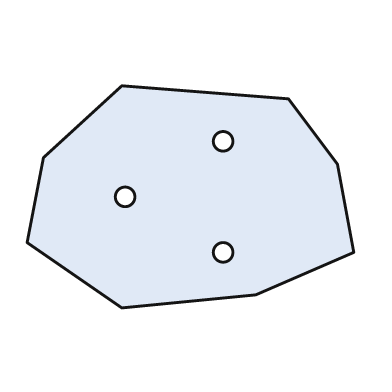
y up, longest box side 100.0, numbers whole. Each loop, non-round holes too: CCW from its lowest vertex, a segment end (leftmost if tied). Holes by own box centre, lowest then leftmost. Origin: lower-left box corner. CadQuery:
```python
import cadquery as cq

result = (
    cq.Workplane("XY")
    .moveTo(29.0, 0.0)
    .lineTo(70.0, 4.0)
    .lineTo(100.0, 17.0)
    .lineTo(95.0, 44.0)
    .lineTo(80.0, 64.0)
    .lineTo(29.0, 68.0)
    .lineTo(5.0, 46.0)
    .lineTo(0.0, 20.0)
    .close()
    .moveTo(60.0, 17.0)
    .circle(3.0)
    .moveTo(30.0, 34.0)
    .circle(3.0)
    .moveTo(60.0, 51.0)
    .circle(3.0)
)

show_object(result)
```